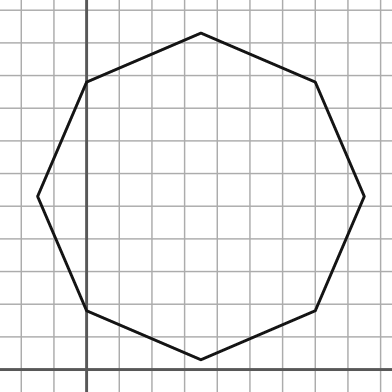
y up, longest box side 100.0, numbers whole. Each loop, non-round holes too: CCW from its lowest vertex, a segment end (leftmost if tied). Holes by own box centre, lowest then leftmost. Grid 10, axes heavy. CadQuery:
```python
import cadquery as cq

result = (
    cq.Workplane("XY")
    .moveTo(35.0, 3.0)
    .lineTo(70.0, 18.0)
    .lineTo(85.0, 53.0)
    .lineTo(70.0, 88.0)
    .lineTo(35.0, 103.0)
    .lineTo(0.0, 88.0)
    .lineTo(-15.0, 53.0)
    .lineTo(0.0, 18.0)
    .close()
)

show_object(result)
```